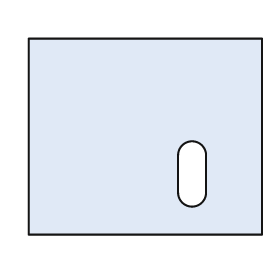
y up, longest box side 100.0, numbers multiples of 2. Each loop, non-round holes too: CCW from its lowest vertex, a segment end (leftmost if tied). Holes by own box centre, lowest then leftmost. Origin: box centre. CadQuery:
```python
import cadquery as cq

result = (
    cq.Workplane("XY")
    .moveTo(-50.0, -42.0)
    .lineTo(50.0, -42.0)
    .lineTo(50.0, 42.0)
    .lineTo(-50.0, 42.0)
    .close()
    .moveTo(14.0, -24.0)
    .threePointArc((20.0, -30.0), (26.0, -24.0))
    .lineTo(26.0, -8.0)
    .threePointArc((20.0, -2.0), (14.0, -8.0))
    .close()
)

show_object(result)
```